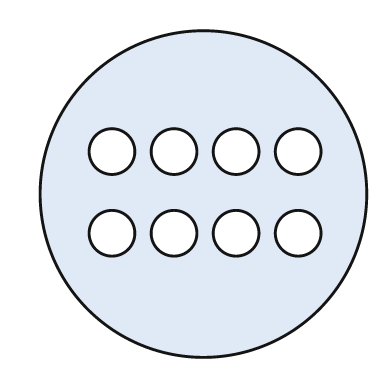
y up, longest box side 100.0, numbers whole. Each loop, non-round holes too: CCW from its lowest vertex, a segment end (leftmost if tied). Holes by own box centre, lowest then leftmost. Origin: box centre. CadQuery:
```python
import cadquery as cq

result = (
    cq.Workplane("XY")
    .moveTo(0.0, 0.0)
    .circle(50.0)
    .moveTo(-28.0, -12.0)
    .circle(7.0)
    .moveTo(-9.0, -12.0)
    .circle(7.0)
    .moveTo(10.0, -12.0)
    .circle(7.0)
    .moveTo(29.0, -12.0)
    .circle(7.0)
    .moveTo(-28.0, 13.0)
    .circle(7.0)
    .moveTo(-9.0, 13.0)
    .circle(7.0)
    .moveTo(10.0, 13.0)
    .circle(7.0)
    .moveTo(29.0, 13.0)
    .circle(7.0)
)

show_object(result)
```